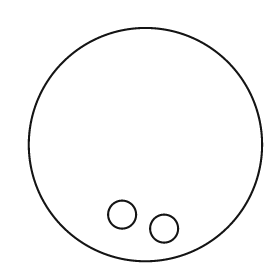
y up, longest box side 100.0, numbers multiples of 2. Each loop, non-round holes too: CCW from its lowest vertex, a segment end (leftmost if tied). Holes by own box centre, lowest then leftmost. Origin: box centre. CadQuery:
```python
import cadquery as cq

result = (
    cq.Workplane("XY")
    .moveTo(0.0, 0.0)
    .circle(50.0)
    .moveTo(8.0, -36.0)
    .circle(6.0)
    .moveTo(-10.0, -30.0)
    .circle(6.0)
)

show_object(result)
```